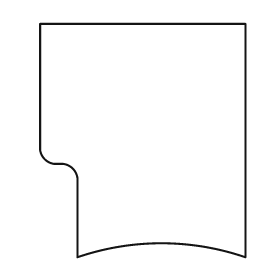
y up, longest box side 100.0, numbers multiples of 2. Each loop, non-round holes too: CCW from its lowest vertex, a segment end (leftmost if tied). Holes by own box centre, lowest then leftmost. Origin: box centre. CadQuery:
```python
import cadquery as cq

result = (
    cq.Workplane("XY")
    .moveTo(-28.0, -50.0)
    .threePointArc((8.0, -44.0), (44.0, -50.0))
    .lineTo(44.0, 50.0)
    .lineTo(-44.0, 50.0)
    .lineTo(-44.0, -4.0)
    .threePointArc((-42.0, -8.0), (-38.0, -10.0))
    .lineTo(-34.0, -10.0)
    .threePointArc((-30.0, -12.0), (-28.0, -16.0))
    .close()
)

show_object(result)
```